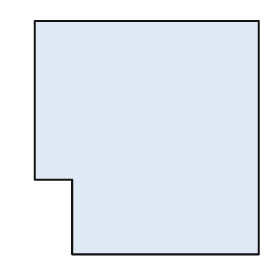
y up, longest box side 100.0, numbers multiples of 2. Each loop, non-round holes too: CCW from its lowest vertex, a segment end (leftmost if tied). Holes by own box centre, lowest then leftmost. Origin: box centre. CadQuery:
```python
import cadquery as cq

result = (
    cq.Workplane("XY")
    .moveTo(-32.0, -50.0)
    .lineTo(48.0, -50.0)
    .lineTo(48.0, 50.0)
    .lineTo(-48.0, 50.0)
    .lineTo(-48.0, -18.0)
    .lineTo(-32.0, -18.0)
    .close()
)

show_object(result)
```